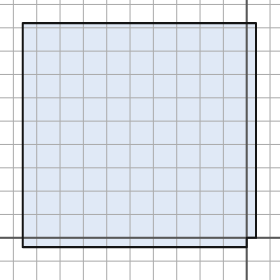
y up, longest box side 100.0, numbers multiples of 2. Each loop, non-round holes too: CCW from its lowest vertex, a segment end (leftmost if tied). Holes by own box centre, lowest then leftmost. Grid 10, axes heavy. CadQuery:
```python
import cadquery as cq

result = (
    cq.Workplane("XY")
    .moveTo(-96.0, -4.0)
    .lineTo(0.0, -4.0)
    .lineTo(0.0, 0.0)
    .lineTo(4.0, 0.0)
    .lineTo(4.0, 92.0)
    .lineTo(-96.0, 92.0)
    .close()
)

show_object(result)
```